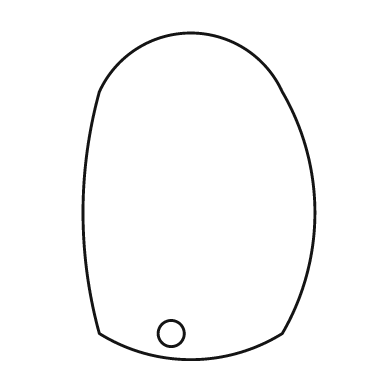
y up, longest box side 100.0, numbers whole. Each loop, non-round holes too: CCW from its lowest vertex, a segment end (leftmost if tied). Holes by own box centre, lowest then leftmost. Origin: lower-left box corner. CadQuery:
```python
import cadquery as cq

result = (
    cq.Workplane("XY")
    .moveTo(5.0, 8.0)
    .threePointArc((33.0, 0.0), (61.0, 8.0))
    .threePointArc((71.0, 45.0), (61.0, 82.0))
    .threePointArc((33.0, 100.0), (5.0, 82.0))
    .threePointArc((0.0, 45.0), (5.0, 8.0))
    .close()
    .moveTo(27.0, 8.0)
    .circle(4.0)
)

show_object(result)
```